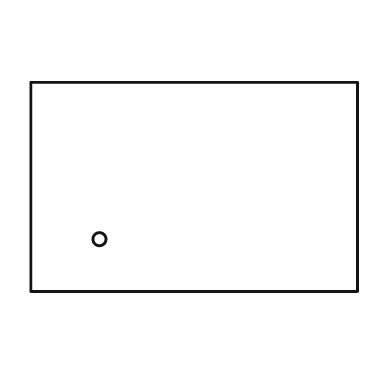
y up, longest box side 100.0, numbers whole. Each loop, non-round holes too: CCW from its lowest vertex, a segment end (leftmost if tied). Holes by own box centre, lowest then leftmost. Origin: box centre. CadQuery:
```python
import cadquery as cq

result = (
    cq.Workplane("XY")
    .moveTo(-50.0, -32.0)
    .lineTo(50.0, -32.0)
    .lineTo(50.0, 32.0)
    .lineTo(-50.0, 32.0)
    .close()
    .moveTo(-29.0, -16.0)
    .circle(2.0)
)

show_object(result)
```